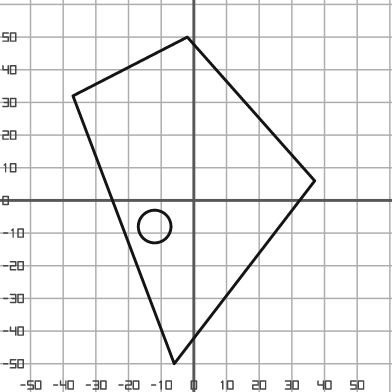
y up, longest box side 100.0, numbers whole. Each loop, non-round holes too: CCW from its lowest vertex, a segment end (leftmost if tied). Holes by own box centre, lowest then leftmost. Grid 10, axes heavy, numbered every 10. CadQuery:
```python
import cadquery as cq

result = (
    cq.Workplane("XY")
    .moveTo(-6.0, -50.0)
    .lineTo(37.0, 6.0)
    .lineTo(-2.0, 50.0)
    .lineTo(-37.0, 32.0)
    .close()
    .moveTo(-12.0, -8.0)
    .circle(5.0)
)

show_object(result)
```